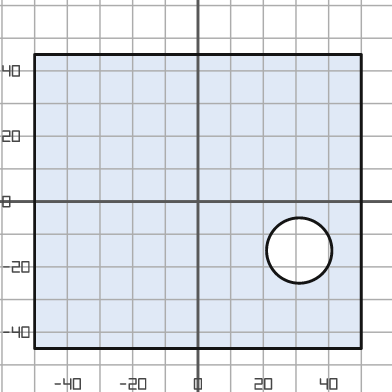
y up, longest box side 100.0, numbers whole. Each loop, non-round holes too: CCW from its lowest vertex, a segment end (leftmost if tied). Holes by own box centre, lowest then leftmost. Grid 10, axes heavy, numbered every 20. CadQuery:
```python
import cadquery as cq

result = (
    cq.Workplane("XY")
    .moveTo(-50.0, -45.0)
    .lineTo(50.0, -45.0)
    .lineTo(50.0, 45.0)
    .lineTo(-50.0, 45.0)
    .close()
    .moveTo(31.0, -15.0)
    .circle(10.0)
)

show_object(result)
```